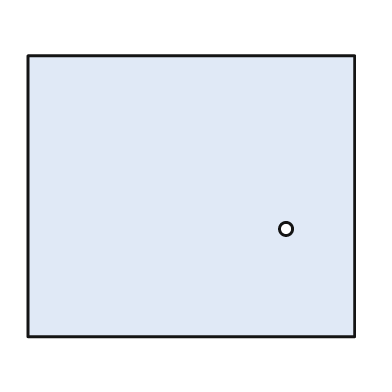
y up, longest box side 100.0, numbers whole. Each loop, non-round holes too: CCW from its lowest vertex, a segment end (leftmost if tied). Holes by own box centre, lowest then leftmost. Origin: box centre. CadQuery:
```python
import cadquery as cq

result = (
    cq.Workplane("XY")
    .moveTo(-50.0, -43.0)
    .lineTo(50.0, -43.0)
    .lineTo(50.0, 43.0)
    .lineTo(-50.0, 43.0)
    .close()
    .moveTo(29.0, -10.0)
    .circle(2.0)
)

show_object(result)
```